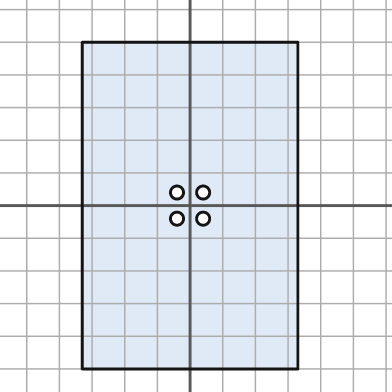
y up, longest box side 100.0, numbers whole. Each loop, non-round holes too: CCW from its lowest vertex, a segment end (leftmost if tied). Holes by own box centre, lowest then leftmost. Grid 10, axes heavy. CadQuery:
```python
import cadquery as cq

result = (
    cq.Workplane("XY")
    .moveTo(-33.0, -50.0)
    .lineTo(33.0, -50.0)
    .lineTo(33.0, 50.0)
    .lineTo(-33.0, 50.0)
    .close()
    .moveTo(-4.0, -4.0)
    .circle(2.0)
    .moveTo(4.0, -4.0)
    .circle(2.0)
    .moveTo(-4.0, 4.0)
    .circle(2.0)
    .moveTo(4.0, 4.0)
    .circle(2.0)
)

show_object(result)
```